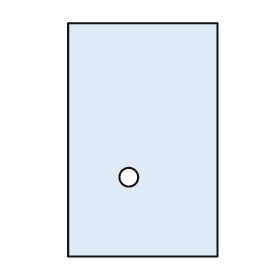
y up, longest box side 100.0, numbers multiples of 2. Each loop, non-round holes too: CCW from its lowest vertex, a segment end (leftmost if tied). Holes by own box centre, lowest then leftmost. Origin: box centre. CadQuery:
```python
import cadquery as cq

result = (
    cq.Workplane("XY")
    .moveTo(-32.0, -50.0)
    .lineTo(32.0, -50.0)
    .lineTo(32.0, 50.0)
    .lineTo(-32.0, 50.0)
    .close()
    .moveTo(-6.0, -16.0)
    .circle(4.0)
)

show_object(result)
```